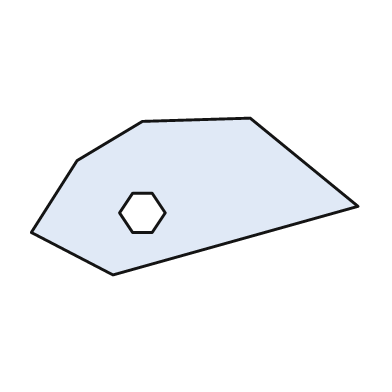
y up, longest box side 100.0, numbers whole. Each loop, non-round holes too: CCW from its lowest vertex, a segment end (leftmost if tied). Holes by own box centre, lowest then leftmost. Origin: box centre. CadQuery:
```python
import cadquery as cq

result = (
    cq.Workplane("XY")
    .moveTo(-25.0, -24.0)
    .lineTo(50.0, -3.0)
    .lineTo(17.0, 24.0)
    .lineTo(-16.0, 23.0)
    .lineTo(-36.0, 11.0)
    .lineTo(-50.0, -11.0)
    .close()
    .moveTo(-19.0, -11.0)
    .lineTo(-13.0, -11.0)
    .lineTo(-9.0, -5.0)
    .lineTo(-13.0, 1.0)
    .lineTo(-19.0, 1.0)
    .lineTo(-23.0, -5.0)
    .close()
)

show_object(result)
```